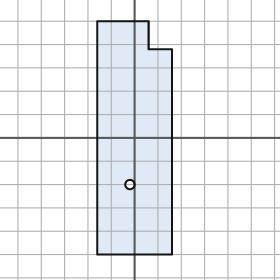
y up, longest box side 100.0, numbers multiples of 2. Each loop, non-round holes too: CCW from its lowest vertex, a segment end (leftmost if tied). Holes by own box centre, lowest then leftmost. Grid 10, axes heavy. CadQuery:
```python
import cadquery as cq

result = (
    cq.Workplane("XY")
    .moveTo(-16.0, -50.0)
    .lineTo(16.0, -50.0)
    .lineTo(16.0, 38.0)
    .lineTo(6.0, 38.0)
    .lineTo(6.0, 50.0)
    .lineTo(-16.0, 50.0)
    .close()
    .moveTo(-2.0, -20.0)
    .circle(2.0)
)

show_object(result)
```